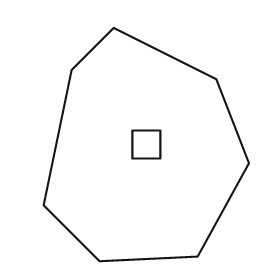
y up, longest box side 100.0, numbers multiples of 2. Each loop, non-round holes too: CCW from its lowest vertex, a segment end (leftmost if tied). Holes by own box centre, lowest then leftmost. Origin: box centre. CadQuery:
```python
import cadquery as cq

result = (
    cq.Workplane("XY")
    .moveTo(-20.0, -50.0)
    .lineTo(22.0, -48.0)
    .lineTo(44.0, -8.0)
    .lineTo(30.0, 28.0)
    .lineTo(-14.0, 50.0)
    .lineTo(-32.0, 32.0)
    .lineTo(-44.0, -26.0)
    .close()
    .moveTo(-6.0, -6.0)
    .lineTo(6.0, -6.0)
    .lineTo(6.0, 6.0)
    .lineTo(-6.0, 6.0)
    .close()
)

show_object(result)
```